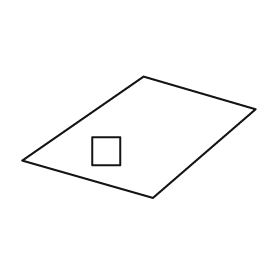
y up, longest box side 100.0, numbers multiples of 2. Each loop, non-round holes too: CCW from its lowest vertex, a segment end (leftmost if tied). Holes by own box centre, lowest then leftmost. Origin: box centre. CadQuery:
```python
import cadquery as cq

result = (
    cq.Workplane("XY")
    .moveTo(6.0, -26.0)
    .lineTo(50.0, 12.0)
    .lineTo(2.0, 26.0)
    .lineTo(-50.0, -10.0)
    .close()
    .moveTo(-20.0, -12.0)
    .lineTo(-8.0, -12.0)
    .lineTo(-8.0, 0.0)
    .lineTo(-20.0, 0.0)
    .close()
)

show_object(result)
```